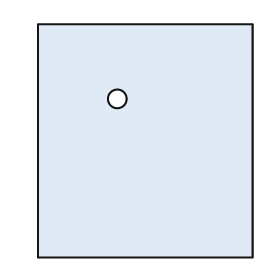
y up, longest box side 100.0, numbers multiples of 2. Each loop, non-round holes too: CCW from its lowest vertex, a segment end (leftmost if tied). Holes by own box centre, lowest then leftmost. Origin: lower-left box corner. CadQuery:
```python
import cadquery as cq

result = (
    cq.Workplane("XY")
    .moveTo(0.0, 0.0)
    .lineTo(92.0, 0.0)
    .lineTo(92.0, 100.0)
    .lineTo(0.0, 100.0)
    .close()
    .moveTo(34.0, 68.0)
    .circle(4.0)
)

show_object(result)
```